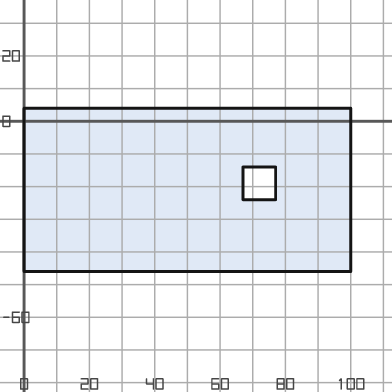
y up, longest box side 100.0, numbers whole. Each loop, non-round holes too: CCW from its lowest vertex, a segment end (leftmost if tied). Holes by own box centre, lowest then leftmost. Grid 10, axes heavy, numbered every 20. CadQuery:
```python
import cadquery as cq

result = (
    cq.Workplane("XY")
    .moveTo(0.0, -46.0)
    .lineTo(100.0, -46.0)
    .lineTo(100.0, 4.0)
    .lineTo(0.0, 4.0)
    .close()
    .moveTo(67.0, -24.0)
    .lineTo(77.0, -24.0)
    .lineTo(77.0, -14.0)
    .lineTo(67.0, -14.0)
    .close()
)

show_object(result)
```